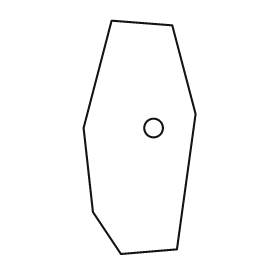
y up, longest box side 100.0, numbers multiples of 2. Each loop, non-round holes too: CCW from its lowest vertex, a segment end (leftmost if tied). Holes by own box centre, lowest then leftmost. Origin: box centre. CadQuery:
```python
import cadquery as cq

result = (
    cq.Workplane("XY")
    .moveTo(-8.0, -50.0)
    .lineTo(16.0, -48.0)
    .lineTo(24.0, 10.0)
    .lineTo(14.0, 48.0)
    .lineTo(-12.0, 50.0)
    .lineTo(-24.0, 4.0)
    .lineTo(-20.0, -32.0)
    .close()
    .moveTo(6.0, 4.0)
    .circle(4.0)
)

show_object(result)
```